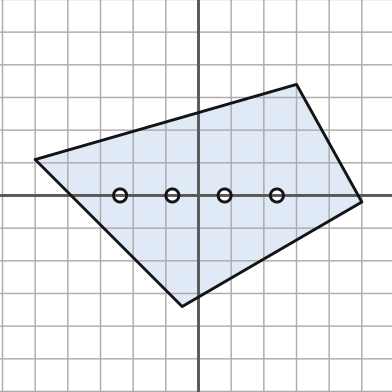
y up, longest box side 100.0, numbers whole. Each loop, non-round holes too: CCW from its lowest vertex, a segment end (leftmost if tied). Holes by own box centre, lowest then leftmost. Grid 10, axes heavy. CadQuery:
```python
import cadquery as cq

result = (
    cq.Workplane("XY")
    .moveTo(-5.0, -34.0)
    .lineTo(50.0, -2.0)
    .lineTo(30.0, 34.0)
    .lineTo(-50.0, 11.0)
    .close()
    .moveTo(-24.0, 0.0)
    .circle(2.0)
    .moveTo(-8.0, 0.0)
    .circle(2.0)
    .moveTo(8.0, 0.0)
    .circle(2.0)
    .moveTo(24.0, 0.0)
    .circle(2.0)
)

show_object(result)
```